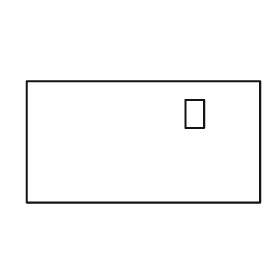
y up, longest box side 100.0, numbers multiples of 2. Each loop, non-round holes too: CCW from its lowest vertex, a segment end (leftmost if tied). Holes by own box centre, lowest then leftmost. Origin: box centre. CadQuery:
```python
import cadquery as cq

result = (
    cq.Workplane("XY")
    .moveTo(-50.0, -26.0)
    .lineTo(50.0, -26.0)
    .lineTo(50.0, 26.0)
    .lineTo(-50.0, 26.0)
    .close()
    .moveTo(18.0, 6.0)
    .lineTo(26.0, 6.0)
    .lineTo(26.0, 18.0)
    .lineTo(18.0, 18.0)
    .close()
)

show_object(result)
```